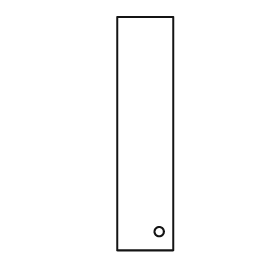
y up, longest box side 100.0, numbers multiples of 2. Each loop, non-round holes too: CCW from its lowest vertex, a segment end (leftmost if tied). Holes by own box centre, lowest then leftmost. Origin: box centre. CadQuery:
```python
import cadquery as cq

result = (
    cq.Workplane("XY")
    .moveTo(-12.0, -50.0)
    .lineTo(12.0, -50.0)
    .lineTo(12.0, 50.0)
    .lineTo(-12.0, 50.0)
    .close()
    .moveTo(6.0, -42.0)
    .circle(2.0)
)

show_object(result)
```